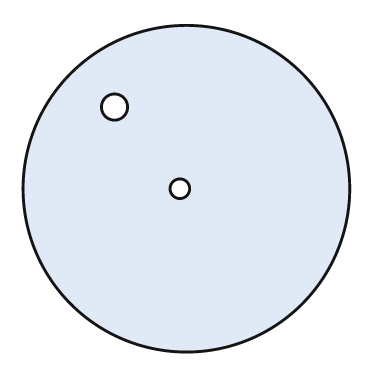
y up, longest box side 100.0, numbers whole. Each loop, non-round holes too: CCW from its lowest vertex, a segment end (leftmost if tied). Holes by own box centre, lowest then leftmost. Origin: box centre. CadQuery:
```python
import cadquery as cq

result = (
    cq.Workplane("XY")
    .moveTo(0.0, 0.0)
    .circle(50.0)
    .moveTo(-2.0, 0.0)
    .circle(3.0)
    .moveTo(-22.0, 25.0)
    .circle(4.0)
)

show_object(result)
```